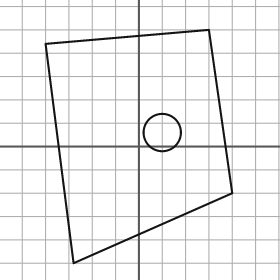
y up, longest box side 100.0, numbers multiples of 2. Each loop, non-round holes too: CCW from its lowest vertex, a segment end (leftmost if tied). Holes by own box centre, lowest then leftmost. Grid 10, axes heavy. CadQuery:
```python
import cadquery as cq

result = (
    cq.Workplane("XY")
    .moveTo(-28.0, -50.0)
    .lineTo(40.0, -20.0)
    .lineTo(30.0, 50.0)
    .lineTo(-40.0, 44.0)
    .close()
    .moveTo(10.0, 6.0)
    .circle(8.0)
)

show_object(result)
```